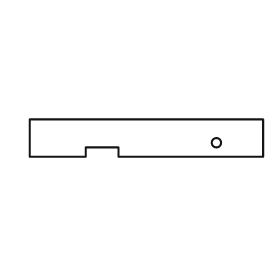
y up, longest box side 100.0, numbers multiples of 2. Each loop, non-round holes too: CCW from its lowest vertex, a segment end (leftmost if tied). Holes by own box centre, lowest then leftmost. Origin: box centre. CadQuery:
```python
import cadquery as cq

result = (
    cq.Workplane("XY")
    .moveTo(-50.0, -8.0)
    .lineTo(-26.0, -8.0)
    .lineTo(-26.0, -4.0)
    .lineTo(-12.0, -4.0)
    .lineTo(-12.0, -8.0)
    .lineTo(50.0, -8.0)
    .lineTo(50.0, 8.0)
    .lineTo(-50.0, 8.0)
    .close()
    .moveTo(30.0, -2.0)
    .circle(2.0)
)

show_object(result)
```